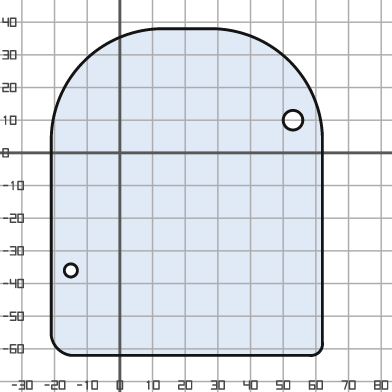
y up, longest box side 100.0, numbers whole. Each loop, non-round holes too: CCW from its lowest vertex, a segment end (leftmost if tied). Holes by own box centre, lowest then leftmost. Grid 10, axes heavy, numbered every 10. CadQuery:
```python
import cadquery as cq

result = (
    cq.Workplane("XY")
    .moveTo(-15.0, -62.0)
    .lineTo(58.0, -62.0)
    .threePointArc((61.0, -61.0), (62.0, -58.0))
    .lineTo(62.0, 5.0)
    .threePointArc((52.0, 28.0), (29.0, 38.0))
    .lineTo(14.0, 38.0)
    .threePointArc((-11.0, 28.0), (-21.0, 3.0))
    .lineTo(-21.0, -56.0)
    .threePointArc((-19.0, -60.0), (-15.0, -62.0))
    .close()
    .moveTo(-15.0, -36.0)
    .circle(2.0)
    .moveTo(53.0, 10.0)
    .circle(3.0)
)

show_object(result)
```